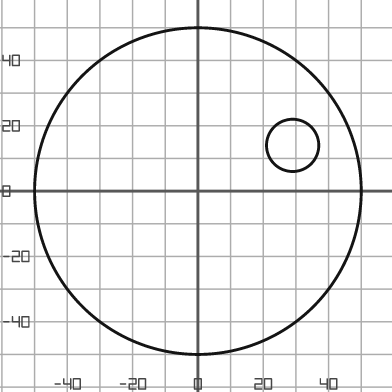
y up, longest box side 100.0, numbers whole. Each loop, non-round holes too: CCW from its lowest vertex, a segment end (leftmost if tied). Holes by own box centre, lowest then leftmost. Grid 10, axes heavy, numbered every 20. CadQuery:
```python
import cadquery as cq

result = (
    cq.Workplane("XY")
    .moveTo(0.0, 0.0)
    .circle(50.0)
    .moveTo(29.0, 14.0)
    .circle(8.0)
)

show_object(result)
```